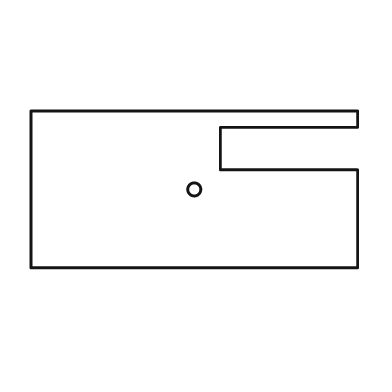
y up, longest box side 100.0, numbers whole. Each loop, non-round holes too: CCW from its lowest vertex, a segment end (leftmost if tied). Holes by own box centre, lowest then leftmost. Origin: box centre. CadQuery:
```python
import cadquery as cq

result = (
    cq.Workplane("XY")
    .moveTo(-50.0, -24.0)
    .lineTo(50.0, -24.0)
    .lineTo(50.0, 6.0)
    .lineTo(8.0, 6.0)
    .lineTo(8.0, 19.0)
    .lineTo(50.0, 19.0)
    .lineTo(50.0, 24.0)
    .lineTo(-50.0, 24.0)
    .close()
    .moveTo(0.0, 0.0)
    .circle(2.0)
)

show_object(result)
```